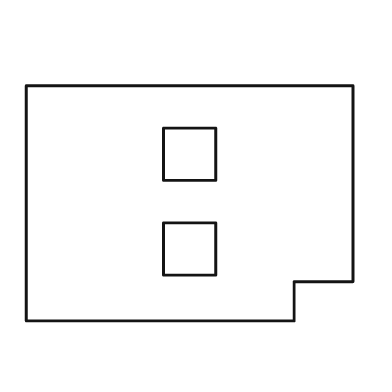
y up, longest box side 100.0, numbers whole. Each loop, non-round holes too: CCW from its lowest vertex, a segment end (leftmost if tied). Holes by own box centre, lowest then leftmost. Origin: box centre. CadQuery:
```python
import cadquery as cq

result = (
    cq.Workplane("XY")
    .moveTo(-50.0, -36.0)
    .lineTo(32.0, -36.0)
    .lineTo(32.0, -24.0)
    .lineTo(50.0, -24.0)
    .lineTo(50.0, 36.0)
    .lineTo(-50.0, 36.0)
    .close()
    .moveTo(-8.0, -22.0)
    .lineTo(8.0, -22.0)
    .lineTo(8.0, -6.0)
    .lineTo(-8.0, -6.0)
    .close()
    .moveTo(-8.0, 7.0)
    .lineTo(8.0, 7.0)
    .lineTo(8.0, 23.0)
    .lineTo(-8.0, 23.0)
    .close()
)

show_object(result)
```